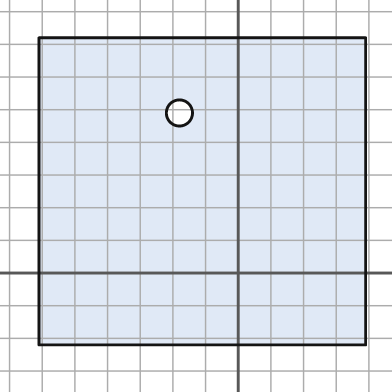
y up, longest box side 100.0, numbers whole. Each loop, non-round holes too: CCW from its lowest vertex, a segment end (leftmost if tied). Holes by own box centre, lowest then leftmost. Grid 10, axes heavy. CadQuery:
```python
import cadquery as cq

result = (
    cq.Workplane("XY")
    .moveTo(-61.0, -22.0)
    .lineTo(39.0, -22.0)
    .lineTo(39.0, 72.0)
    .lineTo(-61.0, 72.0)
    .close()
    .moveTo(-18.0, 49.0)
    .circle(4.0)
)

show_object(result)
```